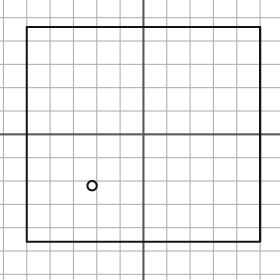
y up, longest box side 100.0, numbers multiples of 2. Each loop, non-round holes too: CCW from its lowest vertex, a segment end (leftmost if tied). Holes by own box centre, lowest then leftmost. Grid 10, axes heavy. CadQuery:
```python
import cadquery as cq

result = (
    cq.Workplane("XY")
    .moveTo(-50.0, -46.0)
    .lineTo(50.0, -46.0)
    .lineTo(50.0, 46.0)
    .lineTo(-50.0, 46.0)
    .close()
    .moveTo(-22.0, -22.0)
    .circle(2.0)
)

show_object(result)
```